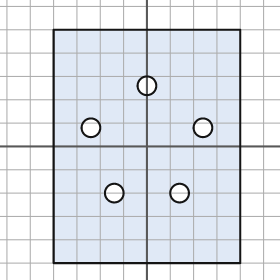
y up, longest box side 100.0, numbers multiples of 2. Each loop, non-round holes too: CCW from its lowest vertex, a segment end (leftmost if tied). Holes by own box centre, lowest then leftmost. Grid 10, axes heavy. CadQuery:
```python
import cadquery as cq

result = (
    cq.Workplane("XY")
    .moveTo(-40.0, -50.0)
    .lineTo(40.0, -50.0)
    .lineTo(40.0, 50.0)
    .lineTo(-40.0, 50.0)
    .close()
    .moveTo(-14.0, -20.0)
    .circle(4.0)
    .moveTo(14.0, -20.0)
    .circle(4.0)
    .moveTo(-24.0, 8.0)
    .circle(4.0)
    .moveTo(24.0, 8.0)
    .circle(4.0)
    .moveTo(0.0, 26.0)
    .circle(4.0)
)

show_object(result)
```